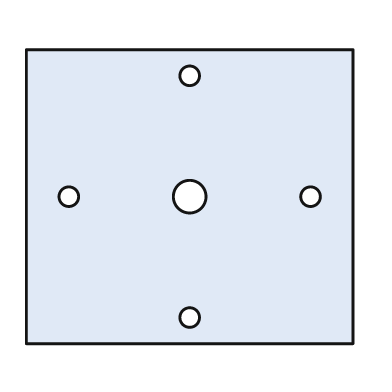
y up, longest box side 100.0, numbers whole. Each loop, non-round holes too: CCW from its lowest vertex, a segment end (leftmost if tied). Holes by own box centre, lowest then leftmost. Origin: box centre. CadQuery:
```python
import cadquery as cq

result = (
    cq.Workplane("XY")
    .moveTo(-50.0, -45.0)
    .lineTo(50.0, -45.0)
    .lineTo(50.0, 45.0)
    .lineTo(-50.0, 45.0)
    .close()
    .moveTo(0.0, -37.0)
    .circle(3.0)
    .moveTo(-37.0, 0.0)
    .circle(3.0)
    .moveTo(0.0, 0.0)
    .circle(5.0)
    .moveTo(37.0, 0.0)
    .circle(3.0)
    .moveTo(0.0, 37.0)
    .circle(3.0)
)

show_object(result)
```